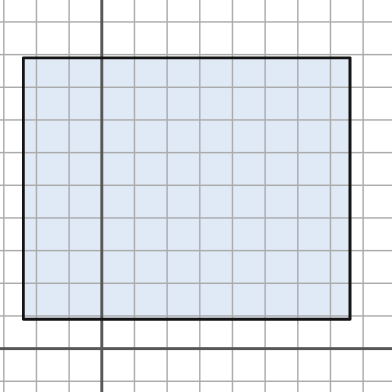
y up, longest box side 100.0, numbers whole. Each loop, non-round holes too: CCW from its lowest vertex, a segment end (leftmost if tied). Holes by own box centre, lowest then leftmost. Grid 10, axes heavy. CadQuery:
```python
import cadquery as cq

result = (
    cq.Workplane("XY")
    .moveTo(-24.0, 9.0)
    .lineTo(76.0, 9.0)
    .lineTo(76.0, 89.0)
    .lineTo(-24.0, 89.0)
    .close()
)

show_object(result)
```